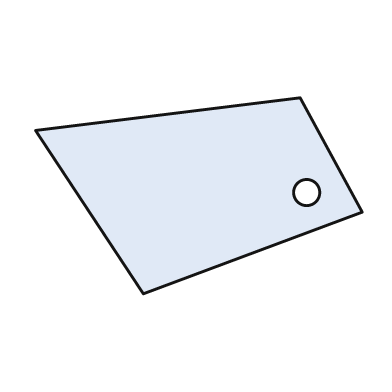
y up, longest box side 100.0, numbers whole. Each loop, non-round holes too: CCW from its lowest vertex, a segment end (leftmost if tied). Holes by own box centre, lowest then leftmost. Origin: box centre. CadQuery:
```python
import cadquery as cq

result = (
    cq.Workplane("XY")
    .moveTo(-17.0, -30.0)
    .lineTo(50.0, -5.0)
    .lineTo(31.0, 30.0)
    .lineTo(-50.0, 20.0)
    .close()
    .moveTo(33.0, 1.0)
    .circle(4.0)
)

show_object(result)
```